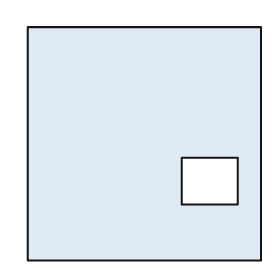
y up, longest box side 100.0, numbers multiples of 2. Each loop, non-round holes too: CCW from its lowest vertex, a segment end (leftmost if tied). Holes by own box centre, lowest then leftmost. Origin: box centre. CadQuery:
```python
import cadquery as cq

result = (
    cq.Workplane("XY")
    .moveTo(-50.0, -50.0)
    .lineTo(50.0, -50.0)
    .lineTo(50.0, 50.0)
    .lineTo(-50.0, 50.0)
    .close()
    .moveTo(16.0, -26.0)
    .lineTo(40.0, -26.0)
    .lineTo(40.0, -6.0)
    .lineTo(16.0, -6.0)
    .close()
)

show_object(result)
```